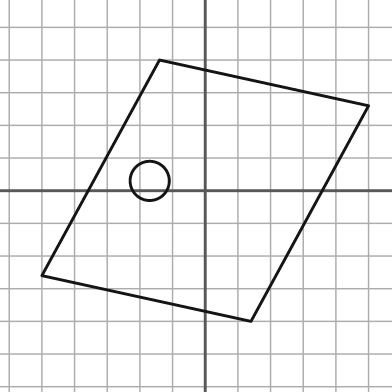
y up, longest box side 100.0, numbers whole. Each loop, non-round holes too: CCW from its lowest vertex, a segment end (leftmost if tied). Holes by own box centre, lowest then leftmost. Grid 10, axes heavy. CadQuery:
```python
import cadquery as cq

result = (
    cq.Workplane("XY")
    .moveTo(14.0, -40.0)
    .lineTo(50.0, 26.0)
    .lineTo(-14.0, 40.0)
    .lineTo(-50.0, -26.0)
    .close()
    .moveTo(-17.0, 3.0)
    .circle(6.0)
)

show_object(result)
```